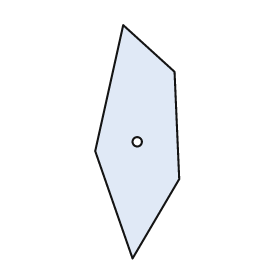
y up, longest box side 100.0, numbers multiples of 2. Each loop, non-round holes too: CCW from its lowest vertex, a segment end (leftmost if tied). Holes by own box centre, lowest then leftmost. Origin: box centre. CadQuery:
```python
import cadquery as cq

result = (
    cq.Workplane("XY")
    .moveTo(-2.0, -50.0)
    .lineTo(18.0, -16.0)
    .lineTo(16.0, 30.0)
    .lineTo(-6.0, 50.0)
    .lineTo(-18.0, -4.0)
    .close()
    .moveTo(0.0, 0.0)
    .circle(2.0)
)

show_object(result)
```